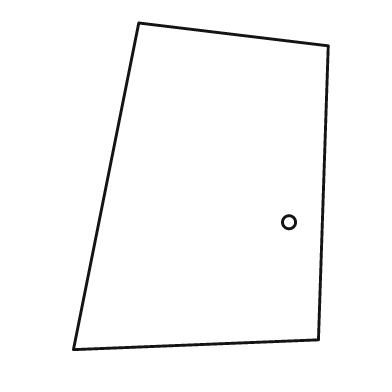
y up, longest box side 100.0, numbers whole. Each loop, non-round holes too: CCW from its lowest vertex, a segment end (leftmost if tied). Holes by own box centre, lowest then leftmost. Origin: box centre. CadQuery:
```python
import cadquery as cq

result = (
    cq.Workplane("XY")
    .moveTo(-39.0, -50.0)
    .lineTo(36.0, -47.0)
    .lineTo(39.0, 43.0)
    .lineTo(-19.0, 50.0)
    .close()
    .moveTo(27.0, -11.0)
    .circle(2.0)
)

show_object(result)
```